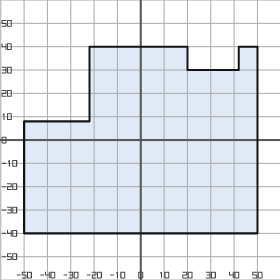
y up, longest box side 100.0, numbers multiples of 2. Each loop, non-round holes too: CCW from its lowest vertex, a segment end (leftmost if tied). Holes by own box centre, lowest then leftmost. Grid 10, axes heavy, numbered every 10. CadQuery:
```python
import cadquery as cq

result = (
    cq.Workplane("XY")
    .moveTo(-50.0, -40.0)
    .lineTo(50.0, -40.0)
    .lineTo(50.0, 40.0)
    .lineTo(42.0, 40.0)
    .lineTo(42.0, 30.0)
    .lineTo(20.0, 30.0)
    .lineTo(20.0, 40.0)
    .lineTo(-22.0, 40.0)
    .lineTo(-22.0, 8.0)
    .lineTo(-50.0, 8.0)
    .close()
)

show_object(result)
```